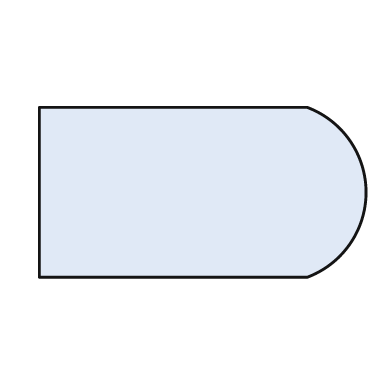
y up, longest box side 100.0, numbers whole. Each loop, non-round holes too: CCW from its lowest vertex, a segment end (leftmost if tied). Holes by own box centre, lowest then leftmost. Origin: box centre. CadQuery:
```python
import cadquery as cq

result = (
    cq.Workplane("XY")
    .moveTo(-50.0, -26.0)
    .lineTo(32.0, -26.0)
    .threePointArc((50.0, 0.0), (32.0, 26.0))
    .lineTo(-50.0, 26.0)
    .close()
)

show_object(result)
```